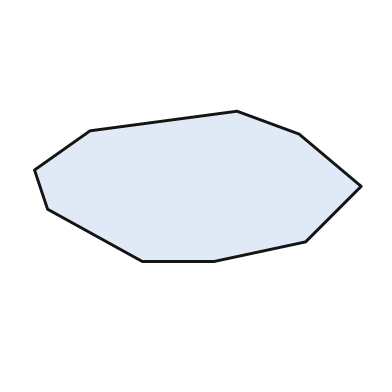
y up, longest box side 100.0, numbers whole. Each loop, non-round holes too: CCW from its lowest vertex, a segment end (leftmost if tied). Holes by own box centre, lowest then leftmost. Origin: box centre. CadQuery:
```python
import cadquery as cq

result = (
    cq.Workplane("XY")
    .moveTo(-17.0, -23.0)
    .lineTo(5.0, -23.0)
    .lineTo(33.0, -17.0)
    .lineTo(50.0, 0.0)
    .lineTo(31.0, 16.0)
    .lineTo(12.0, 23.0)
    .lineTo(-33.0, 17.0)
    .lineTo(-50.0, 5.0)
    .lineTo(-46.0, -7.0)
    .close()
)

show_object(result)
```